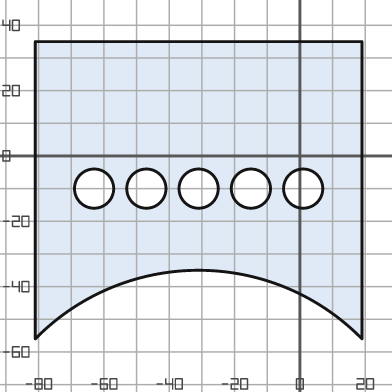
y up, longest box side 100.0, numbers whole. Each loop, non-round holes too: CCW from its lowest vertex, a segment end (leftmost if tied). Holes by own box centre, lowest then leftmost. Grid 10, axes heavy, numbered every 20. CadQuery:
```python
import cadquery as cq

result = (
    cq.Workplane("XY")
    .moveTo(-81.0, -56.0)
    .threePointArc((-31.0, -35.0), (19.0, -56.0))
    .lineTo(19.0, 35.0)
    .lineTo(-81.0, 35.0)
    .close()
    .moveTo(-63.0, -10.0)
    .circle(6.0)
    .moveTo(-47.0, -10.0)
    .circle(6.0)
    .moveTo(-31.0, -10.0)
    .circle(6.0)
    .moveTo(-15.0, -10.0)
    .circle(6.0)
    .moveTo(1.0, -10.0)
    .circle(6.0)
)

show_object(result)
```